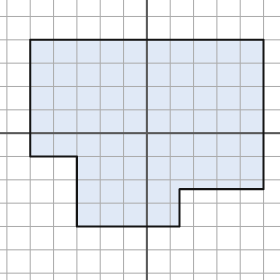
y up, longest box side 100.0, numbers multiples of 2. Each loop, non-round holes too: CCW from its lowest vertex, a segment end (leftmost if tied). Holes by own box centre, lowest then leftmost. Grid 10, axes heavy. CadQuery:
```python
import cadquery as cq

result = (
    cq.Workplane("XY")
    .moveTo(-30.0, -40.0)
    .lineTo(14.0, -40.0)
    .lineTo(14.0, -24.0)
    .lineTo(50.0, -24.0)
    .lineTo(50.0, 40.0)
    .lineTo(-50.0, 40.0)
    .lineTo(-50.0, -10.0)
    .lineTo(-30.0, -10.0)
    .close()
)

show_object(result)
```